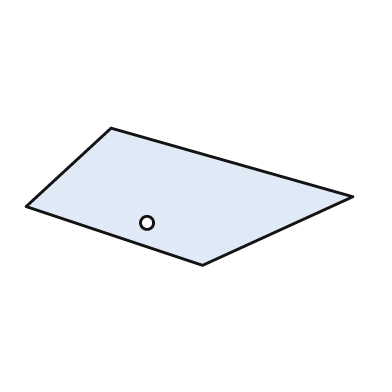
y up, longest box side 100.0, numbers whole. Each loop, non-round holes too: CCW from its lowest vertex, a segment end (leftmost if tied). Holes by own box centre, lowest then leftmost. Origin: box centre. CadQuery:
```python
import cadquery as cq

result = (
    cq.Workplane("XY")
    .moveTo(4.0, -21.0)
    .lineTo(50.0, 0.0)
    .lineTo(-24.0, 21.0)
    .lineTo(-50.0, -3.0)
    .close()
    .moveTo(-13.0, -8.0)
    .circle(2.0)
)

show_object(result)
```